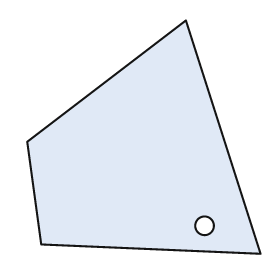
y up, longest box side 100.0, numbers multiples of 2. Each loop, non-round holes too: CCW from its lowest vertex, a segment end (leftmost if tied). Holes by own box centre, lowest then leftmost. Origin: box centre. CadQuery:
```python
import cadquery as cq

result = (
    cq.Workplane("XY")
    .moveTo(50.0, -50.0)
    .lineTo(18.0, 50.0)
    .lineTo(-50.0, -2.0)
    .lineTo(-44.0, -46.0)
    .close()
    .moveTo(26.0, -38.0)
    .circle(4.0)
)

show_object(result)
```